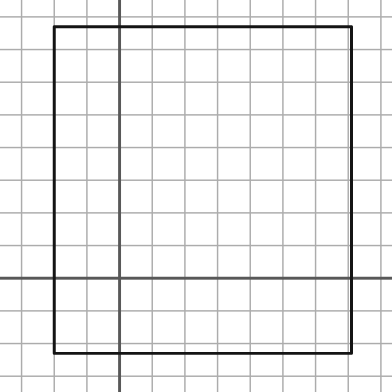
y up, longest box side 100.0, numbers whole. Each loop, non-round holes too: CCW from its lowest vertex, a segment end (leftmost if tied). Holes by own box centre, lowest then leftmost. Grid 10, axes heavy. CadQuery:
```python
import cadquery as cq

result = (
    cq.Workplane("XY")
    .moveTo(-20.0, -23.0)
    .lineTo(71.0, -23.0)
    .lineTo(71.0, 77.0)
    .lineTo(-20.0, 77.0)
    .close()
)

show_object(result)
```